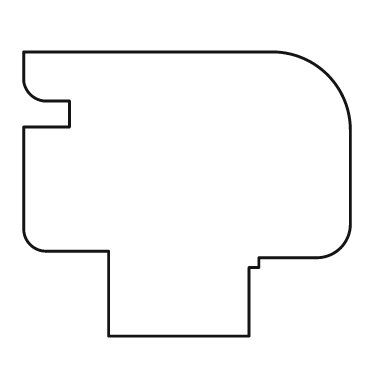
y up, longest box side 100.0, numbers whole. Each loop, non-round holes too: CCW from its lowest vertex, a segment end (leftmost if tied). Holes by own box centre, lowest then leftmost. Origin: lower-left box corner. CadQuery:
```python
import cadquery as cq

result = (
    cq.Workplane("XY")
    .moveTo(26.0, 0.0)
    .lineTo(69.0, 0.0)
    .lineTo(69.0, 21.0)
    .lineTo(72.0, 21.0)
    .lineTo(72.0, 24.0)
    .lineTo(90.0, 24.0)
    .threePointArc((97.0, 27.0), (100.0, 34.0))
    .lineTo(100.0, 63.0)
    .threePointArc((93.0, 80.0), (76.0, 87.0))
    .lineTo(0.0, 87.0)
    .lineTo(0.0, 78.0)
    .threePointArc((2.0, 74.0), (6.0, 72.0))
    .lineTo(14.0, 72.0)
    .lineTo(14.0, 64.0)
    .lineTo(0.0, 64.0)
    .lineTo(0.0, 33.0)
    .threePointArc((2.0, 28.0), (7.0, 26.0))
    .lineTo(26.0, 26.0)
    .close()
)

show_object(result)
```